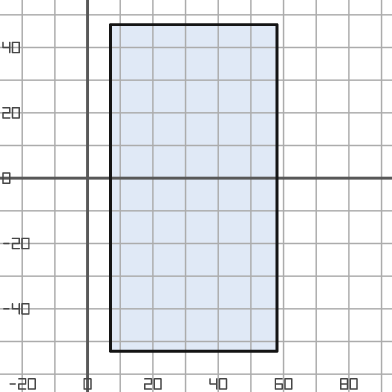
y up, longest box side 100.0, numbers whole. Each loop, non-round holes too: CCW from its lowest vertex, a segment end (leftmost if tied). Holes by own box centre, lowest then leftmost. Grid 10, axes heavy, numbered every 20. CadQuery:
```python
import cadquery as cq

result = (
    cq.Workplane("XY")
    .moveTo(7.0, -53.0)
    .lineTo(58.0, -53.0)
    .lineTo(58.0, 47.0)
    .lineTo(7.0, 47.0)
    .close()
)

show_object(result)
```